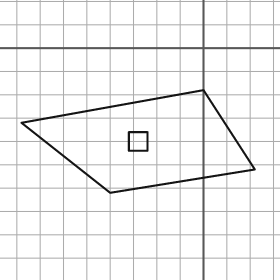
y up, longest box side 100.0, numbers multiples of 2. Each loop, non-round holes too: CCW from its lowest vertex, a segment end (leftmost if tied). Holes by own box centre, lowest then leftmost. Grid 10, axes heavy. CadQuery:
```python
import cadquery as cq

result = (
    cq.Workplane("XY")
    .moveTo(-40.0, -62.0)
    .lineTo(22.0, -52.0)
    .lineTo(0.0, -18.0)
    .lineTo(-78.0, -32.0)
    .close()
    .moveTo(-32.0, -44.0)
    .lineTo(-24.0, -44.0)
    .lineTo(-24.0, -36.0)
    .lineTo(-32.0, -36.0)
    .close()
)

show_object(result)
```